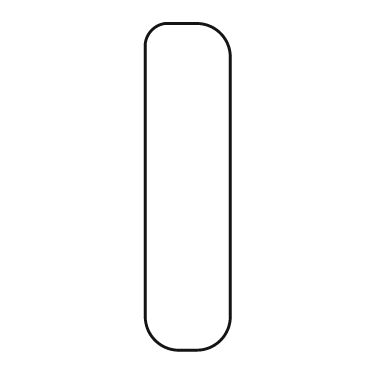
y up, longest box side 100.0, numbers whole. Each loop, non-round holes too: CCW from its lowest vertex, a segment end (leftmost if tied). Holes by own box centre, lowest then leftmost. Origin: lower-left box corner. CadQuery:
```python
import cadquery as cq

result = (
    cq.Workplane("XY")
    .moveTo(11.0, 0.0)
    .lineTo(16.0, 0.0)
    .threePointArc((23.0, 3.0), (26.0, 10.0))
    .lineTo(26.0, 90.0)
    .threePointArc((23.0, 97.0), (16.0, 100.0))
    .lineTo(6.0, 100.0)
    .threePointArc((2.0, 98.0), (0.0, 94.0))
    .lineTo(0.0, 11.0)
    .threePointArc((3.0, 3.0), (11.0, 0.0))
    .close()
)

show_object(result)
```